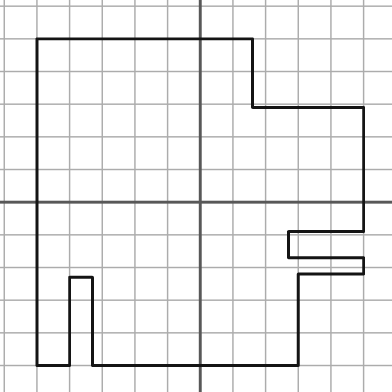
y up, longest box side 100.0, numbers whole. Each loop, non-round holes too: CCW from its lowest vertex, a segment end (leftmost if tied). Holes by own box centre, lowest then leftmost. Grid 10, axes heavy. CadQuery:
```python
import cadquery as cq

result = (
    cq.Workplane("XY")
    .moveTo(-50.0, -50.0)
    .lineTo(-40.0, -50.0)
    .lineTo(-40.0, -23.0)
    .lineTo(-33.0, -23.0)
    .lineTo(-33.0, -50.0)
    .lineTo(30.0, -50.0)
    .lineTo(30.0, -22.0)
    .lineTo(50.0, -22.0)
    .lineTo(50.0, -17.0)
    .lineTo(27.0, -17.0)
    .lineTo(27.0, -9.0)
    .lineTo(50.0, -9.0)
    .lineTo(50.0, 29.0)
    .lineTo(16.0, 29.0)
    .lineTo(16.0, 50.0)
    .lineTo(-50.0, 50.0)
    .close()
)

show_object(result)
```